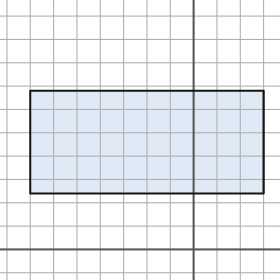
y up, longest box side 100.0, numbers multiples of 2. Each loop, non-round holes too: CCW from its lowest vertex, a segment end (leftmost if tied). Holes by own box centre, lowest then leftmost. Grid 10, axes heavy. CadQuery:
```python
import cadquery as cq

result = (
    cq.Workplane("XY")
    .moveTo(-70.0, 24.0)
    .lineTo(30.0, 24.0)
    .lineTo(30.0, 68.0)
    .lineTo(-70.0, 68.0)
    .close()
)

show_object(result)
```